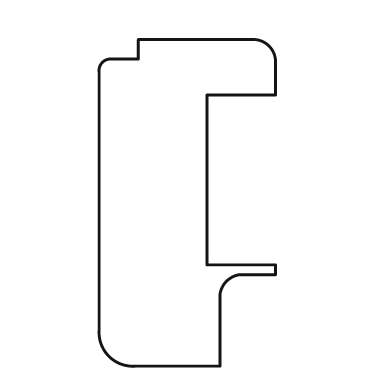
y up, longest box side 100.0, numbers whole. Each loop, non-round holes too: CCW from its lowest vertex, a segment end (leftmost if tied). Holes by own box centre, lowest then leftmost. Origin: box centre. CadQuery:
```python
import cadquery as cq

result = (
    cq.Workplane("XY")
    .moveTo(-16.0, -50.0)
    .lineTo(10.0, -50.0)
    .lineTo(10.0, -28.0)
    .threePointArc((12.0, -24.0), (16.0, -22.0))
    .lineTo(27.0, -22.0)
    .lineTo(27.0, -19.0)
    .lineTo(6.0, -19.0)
    .lineTo(6.0, 33.0)
    .lineTo(27.0, 33.0)
    .lineTo(27.0, 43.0)
    .threePointArc((25.0, 48.0), (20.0, 50.0))
    .lineTo(-15.0, 50.0)
    .lineTo(-15.0, 44.0)
    .lineTo(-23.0, 44.0)
    .threePointArc((-26.0, 43.0), (-27.0, 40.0))
    .lineTo(-27.0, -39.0)
    .threePointArc((-24.0, -47.0), (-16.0, -50.0))
    .close()
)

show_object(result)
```